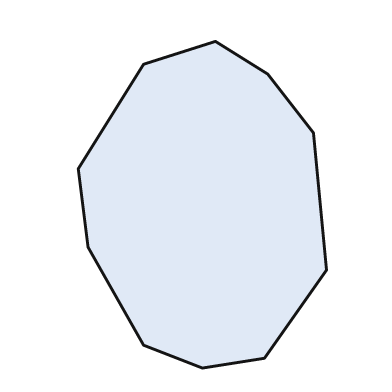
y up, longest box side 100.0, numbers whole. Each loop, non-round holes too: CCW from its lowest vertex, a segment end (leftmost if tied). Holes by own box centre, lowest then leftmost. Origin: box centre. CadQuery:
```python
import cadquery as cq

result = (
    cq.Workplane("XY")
    .moveTo(0.0, -50.0)
    .lineTo(19.0, -47.0)
    .lineTo(38.0, -20.0)
    .lineTo(34.0, 22.0)
    .lineTo(20.0, 40.0)
    .lineTo(4.0, 50.0)
    .lineTo(-18.0, 43.0)
    .lineTo(-38.0, 11.0)
    .lineTo(-35.0, -13.0)
    .lineTo(-18.0, -43.0)
    .close()
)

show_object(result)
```